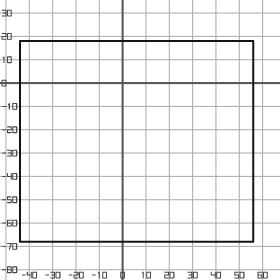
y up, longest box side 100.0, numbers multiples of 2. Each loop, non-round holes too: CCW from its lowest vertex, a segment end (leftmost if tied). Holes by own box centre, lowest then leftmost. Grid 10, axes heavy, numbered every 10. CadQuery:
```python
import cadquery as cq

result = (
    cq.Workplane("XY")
    .moveTo(-44.0, -68.0)
    .lineTo(56.0, -68.0)
    .lineTo(56.0, 18.0)
    .lineTo(-44.0, 18.0)
    .close()
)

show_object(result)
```